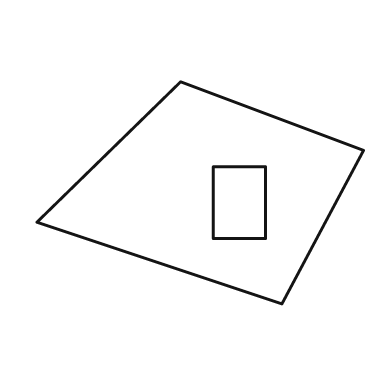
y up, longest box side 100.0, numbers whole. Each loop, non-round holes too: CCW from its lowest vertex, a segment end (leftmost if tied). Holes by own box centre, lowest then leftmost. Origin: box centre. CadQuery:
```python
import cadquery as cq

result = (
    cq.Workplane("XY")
    .moveTo(25.0, -34.0)
    .lineTo(50.0, 13.0)
    .lineTo(-6.0, 34.0)
    .lineTo(-50.0, -9.0)
    .close()
    .moveTo(4.0, -14.0)
    .lineTo(20.0, -14.0)
    .lineTo(20.0, 8.0)
    .lineTo(4.0, 8.0)
    .close()
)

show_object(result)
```